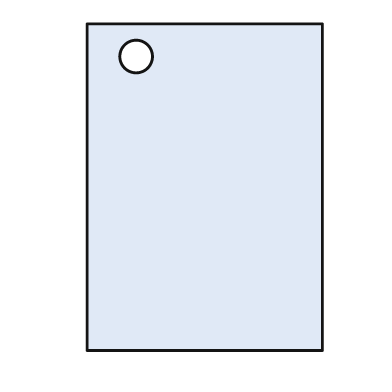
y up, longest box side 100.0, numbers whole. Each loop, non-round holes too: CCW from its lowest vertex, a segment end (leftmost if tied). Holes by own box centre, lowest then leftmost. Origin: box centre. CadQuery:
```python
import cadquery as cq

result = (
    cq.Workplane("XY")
    .moveTo(-36.0, -50.0)
    .lineTo(36.0, -50.0)
    .lineTo(36.0, 50.0)
    .lineTo(-36.0, 50.0)
    .close()
    .moveTo(-21.0, 40.0)
    .circle(5.0)
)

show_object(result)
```